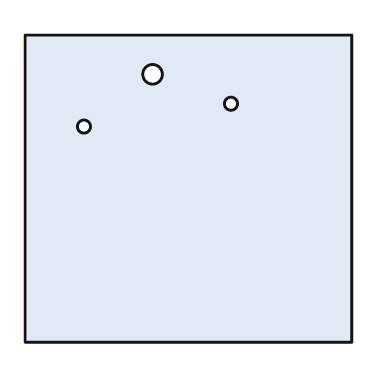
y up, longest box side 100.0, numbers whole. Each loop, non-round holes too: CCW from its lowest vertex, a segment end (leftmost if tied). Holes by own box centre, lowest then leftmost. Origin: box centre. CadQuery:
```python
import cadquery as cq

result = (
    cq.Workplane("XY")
    .moveTo(-50.0, -47.0)
    .lineTo(50.0, -47.0)
    .lineTo(50.0, 47.0)
    .lineTo(-50.0, 47.0)
    .close()
    .moveTo(-32.0, 19.0)
    .circle(2.0)
    .moveTo(13.0, 26.0)
    .circle(2.0)
    .moveTo(-11.0, 35.0)
    .circle(3.0)
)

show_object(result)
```